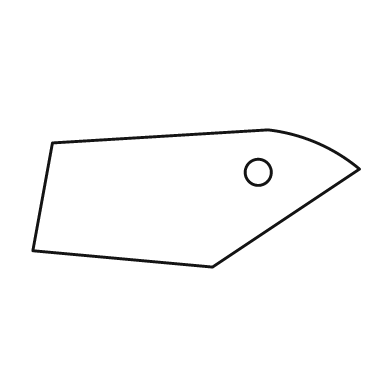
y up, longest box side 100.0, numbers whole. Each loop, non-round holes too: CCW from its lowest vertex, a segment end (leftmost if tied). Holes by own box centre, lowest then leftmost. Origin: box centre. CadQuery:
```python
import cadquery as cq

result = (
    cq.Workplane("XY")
    .moveTo(5.0, -21.0)
    .lineTo(50.0, 9.0)
    .threePointArc((37.0, 17.0), (22.0, 21.0))
    .lineTo(-44.0, 17.0)
    .lineTo(-50.0, -16.0)
    .close()
    .moveTo(19.0, 8.0)
    .circle(4.0)
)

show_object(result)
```